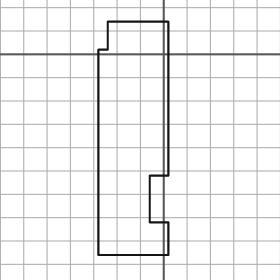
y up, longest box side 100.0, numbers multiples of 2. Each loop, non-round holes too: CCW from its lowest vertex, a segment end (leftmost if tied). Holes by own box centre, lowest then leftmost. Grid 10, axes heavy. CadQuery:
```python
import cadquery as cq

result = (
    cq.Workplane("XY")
    .moveTo(-28.0, -86.0)
    .lineTo(2.0, -86.0)
    .lineTo(2.0, -72.0)
    .lineTo(-6.0, -72.0)
    .lineTo(-6.0, -52.0)
    .lineTo(2.0, -52.0)
    .lineTo(2.0, 14.0)
    .lineTo(-24.0, 14.0)
    .lineTo(-24.0, 2.0)
    .lineTo(-28.0, 2.0)
    .close()
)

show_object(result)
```